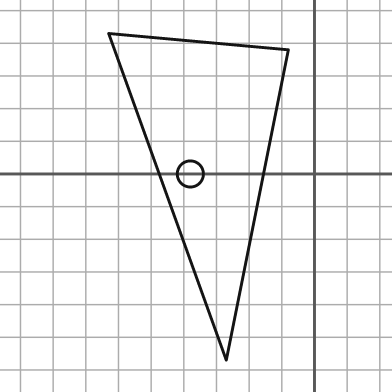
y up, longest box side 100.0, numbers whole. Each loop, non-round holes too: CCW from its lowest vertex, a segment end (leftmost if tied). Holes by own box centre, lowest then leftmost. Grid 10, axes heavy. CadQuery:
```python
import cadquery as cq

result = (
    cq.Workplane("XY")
    .moveTo(-27.0, -57.0)
    .lineTo(-8.0, 38.0)
    .lineTo(-63.0, 43.0)
    .close()
    .moveTo(-38.0, 0.0)
    .circle(4.0)
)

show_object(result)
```